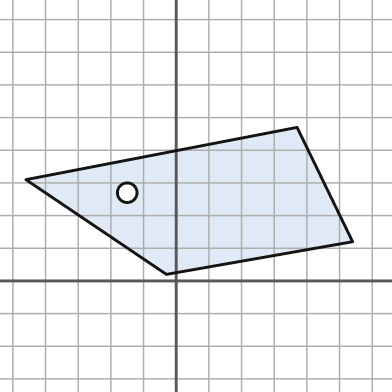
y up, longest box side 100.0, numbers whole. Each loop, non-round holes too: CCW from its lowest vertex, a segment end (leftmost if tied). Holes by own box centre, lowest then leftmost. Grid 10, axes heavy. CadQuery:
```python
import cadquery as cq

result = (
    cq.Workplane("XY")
    .moveTo(-3.0, 2.0)
    .lineTo(54.0, 12.0)
    .lineTo(37.0, 47.0)
    .lineTo(-46.0, 31.0)
    .close()
    .moveTo(-15.0, 27.0)
    .circle(3.0)
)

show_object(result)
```